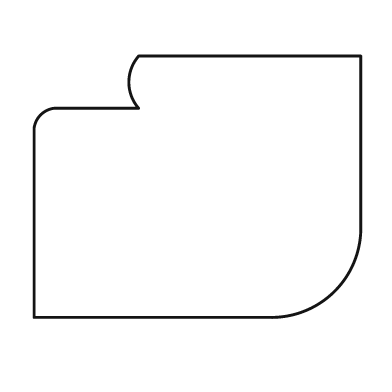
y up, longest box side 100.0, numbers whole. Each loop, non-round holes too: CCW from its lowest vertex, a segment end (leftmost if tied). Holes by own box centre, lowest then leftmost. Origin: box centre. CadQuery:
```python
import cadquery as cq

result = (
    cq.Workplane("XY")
    .moveTo(-50.0, -40.0)
    .lineTo(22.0, -40.0)
    .threePointArc((42.0, -32.0), (50.0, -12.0))
    .lineTo(50.0, 40.0)
    .lineTo(-18.0, 40.0)
    .threePointArc((-21.0, 32.0), (-18.0, 24.0))
    .lineTo(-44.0, 24.0)
    .threePointArc((-48.0, 22.0), (-50.0, 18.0))
    .close()
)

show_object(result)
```